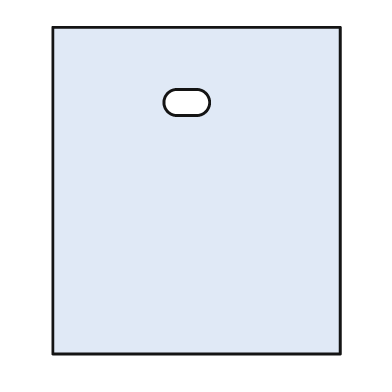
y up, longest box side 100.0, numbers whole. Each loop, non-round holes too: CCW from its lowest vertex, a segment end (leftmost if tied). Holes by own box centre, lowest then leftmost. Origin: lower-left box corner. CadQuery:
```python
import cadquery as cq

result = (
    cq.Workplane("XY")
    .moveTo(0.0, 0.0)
    .lineTo(88.0, 0.0)
    .lineTo(88.0, 100.0)
    .lineTo(0.0, 100.0)
    .close()
    .moveTo(38.0, 73.0)
    .lineTo(44.0, 73.0)
    .threePointArc((48.0, 77.0), (44.0, 81.0))
    .lineTo(38.0, 81.0)
    .threePointArc((34.0, 77.0), (38.0, 73.0))
    .close()
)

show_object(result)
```